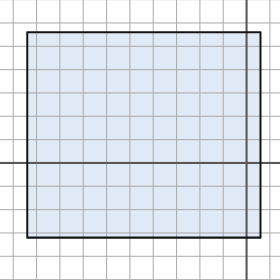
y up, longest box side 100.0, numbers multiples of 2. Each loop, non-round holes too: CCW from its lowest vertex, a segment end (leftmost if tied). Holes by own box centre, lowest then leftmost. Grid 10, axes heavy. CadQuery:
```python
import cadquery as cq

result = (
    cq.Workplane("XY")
    .moveTo(-94.0, -32.0)
    .lineTo(6.0, -32.0)
    .lineTo(6.0, 56.0)
    .lineTo(-94.0, 56.0)
    .close()
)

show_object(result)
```